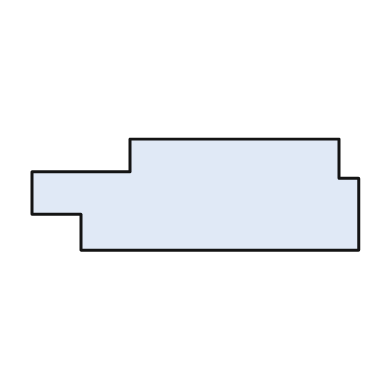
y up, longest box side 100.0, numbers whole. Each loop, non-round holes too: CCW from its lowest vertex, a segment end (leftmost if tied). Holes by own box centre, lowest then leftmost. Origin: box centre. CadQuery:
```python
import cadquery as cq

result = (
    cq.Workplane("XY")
    .moveTo(-35.0, -17.0)
    .lineTo(50.0, -17.0)
    .lineTo(50.0, 5.0)
    .lineTo(44.0, 5.0)
    .lineTo(44.0, 17.0)
    .lineTo(-20.0, 17.0)
    .lineTo(-20.0, 7.0)
    .lineTo(-50.0, 7.0)
    .lineTo(-50.0, -6.0)
    .lineTo(-35.0, -6.0)
    .close()
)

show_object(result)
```